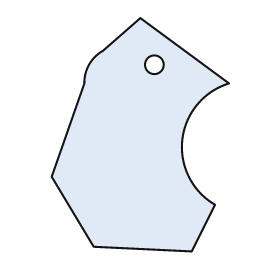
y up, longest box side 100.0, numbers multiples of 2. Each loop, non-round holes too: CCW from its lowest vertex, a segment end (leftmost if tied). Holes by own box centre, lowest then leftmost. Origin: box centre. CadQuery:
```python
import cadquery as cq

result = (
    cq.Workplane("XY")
    .moveTo(22.0, -50.0)
    .lineTo(32.0, -30.0)
    .threePointArc((18.0, -2.0), (38.0, 22.0))
    .lineTo(0.0, 50.0)
    .lineTo(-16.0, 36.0)
    .threePointArc((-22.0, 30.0), (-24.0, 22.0))
    .lineTo(-38.0, -18.0)
    .lineTo(-20.0, -48.0)
    .close()
    .moveTo(6.0, 30.0)
    .circle(4.0)
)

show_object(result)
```